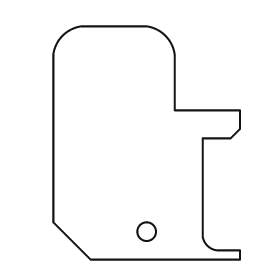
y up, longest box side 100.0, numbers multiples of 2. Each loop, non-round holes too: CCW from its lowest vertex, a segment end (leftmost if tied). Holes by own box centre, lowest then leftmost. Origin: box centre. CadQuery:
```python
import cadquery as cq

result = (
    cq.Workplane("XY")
    .moveTo(-24.0, -50.0)
    .lineTo(40.0, -50.0)
    .lineTo(40.0, -46.0)
    .lineTo(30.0, -46.0)
    .threePointArc((26.0, -44.0), (24.0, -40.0))
    .lineTo(24.0, 2.0)
    .lineTo(36.0, 2.0)
    .lineTo(40.0, 6.0)
    .lineTo(40.0, 14.0)
    .lineTo(12.0, 14.0)
    .lineTo(12.0, 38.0)
    .threePointArc((8.0, 46.0), (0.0, 50.0))
    .lineTo(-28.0, 50.0)
    .threePointArc((-36.0, 46.0), (-40.0, 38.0))
    .lineTo(-40.0, -34.0)
    .close()
    .moveTo(0.0, -38.0)
    .circle(4.0)
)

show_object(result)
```